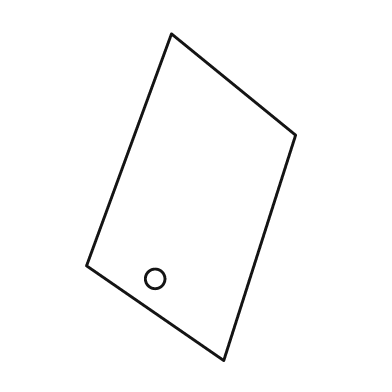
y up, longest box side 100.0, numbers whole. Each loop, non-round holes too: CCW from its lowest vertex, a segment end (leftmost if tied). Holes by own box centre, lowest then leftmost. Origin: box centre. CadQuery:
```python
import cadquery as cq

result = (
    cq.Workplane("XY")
    .moveTo(10.0, -50.0)
    .lineTo(32.0, 19.0)
    .lineTo(-6.0, 50.0)
    .lineTo(-32.0, -21.0)
    .close()
    .moveTo(-11.0, -25.0)
    .circle(3.0)
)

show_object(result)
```